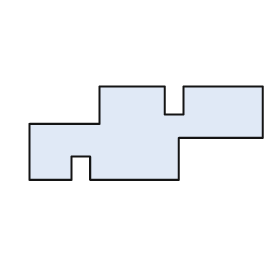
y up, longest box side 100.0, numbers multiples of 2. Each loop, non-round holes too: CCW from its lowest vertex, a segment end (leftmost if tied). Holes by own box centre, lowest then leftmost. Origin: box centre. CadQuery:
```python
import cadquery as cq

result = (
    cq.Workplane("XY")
    .moveTo(-50.0, -20.0)
    .lineTo(-32.0, -20.0)
    .lineTo(-32.0, -10.0)
    .lineTo(-24.0, -10.0)
    .lineTo(-24.0, -20.0)
    .lineTo(14.0, -20.0)
    .lineTo(14.0, -2.0)
    .lineTo(50.0, -2.0)
    .lineTo(50.0, 20.0)
    .lineTo(16.0, 20.0)
    .lineTo(16.0, 8.0)
    .lineTo(8.0, 8.0)
    .lineTo(8.0, 20.0)
    .lineTo(-20.0, 20.0)
    .lineTo(-20.0, 4.0)
    .lineTo(-50.0, 4.0)
    .close()
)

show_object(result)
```